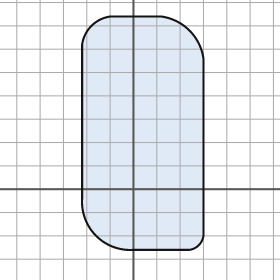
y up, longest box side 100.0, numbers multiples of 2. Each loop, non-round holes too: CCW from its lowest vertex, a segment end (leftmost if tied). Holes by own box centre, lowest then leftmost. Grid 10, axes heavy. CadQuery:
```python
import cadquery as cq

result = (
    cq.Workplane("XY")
    .moveTo(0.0, -26.0)
    .lineTo(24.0, -26.0)
    .threePointArc((28.0, -24.0), (30.0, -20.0))
    .lineTo(30.0, 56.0)
    .threePointArc((24.0, 68.0), (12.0, 74.0))
    .lineTo(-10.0, 74.0)
    .threePointArc((-18.0, 70.0), (-22.0, 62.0))
    .lineTo(-22.0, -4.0)
    .threePointArc((-16.0, -20.0), (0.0, -26.0))
    .close()
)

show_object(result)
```